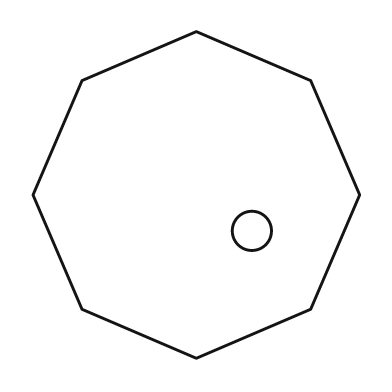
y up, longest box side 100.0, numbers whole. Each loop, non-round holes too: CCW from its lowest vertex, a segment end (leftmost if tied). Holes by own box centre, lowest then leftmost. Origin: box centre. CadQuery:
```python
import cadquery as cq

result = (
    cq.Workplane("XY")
    .moveTo(0.0, -50.0)
    .lineTo(35.0, -35.0)
    .lineTo(50.0, 0.0)
    .lineTo(35.0, 35.0)
    .lineTo(0.0, 50.0)
    .lineTo(-35.0, 35.0)
    .lineTo(-50.0, 0.0)
    .lineTo(-35.0, -35.0)
    .close()
    .moveTo(17.0, -11.0)
    .circle(6.0)
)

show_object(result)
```